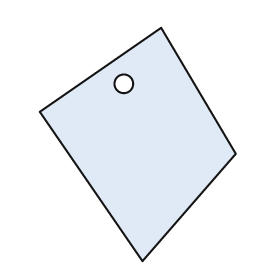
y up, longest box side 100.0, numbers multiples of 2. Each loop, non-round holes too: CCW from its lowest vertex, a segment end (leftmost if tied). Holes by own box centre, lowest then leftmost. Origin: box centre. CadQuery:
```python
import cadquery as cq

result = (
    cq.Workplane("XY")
    .moveTo(2.0, -50.0)
    .lineTo(42.0, -4.0)
    .lineTo(10.0, 50.0)
    .lineTo(-42.0, 14.0)
    .close()
    .moveTo(-6.0, 26.0)
    .circle(4.0)
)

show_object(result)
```